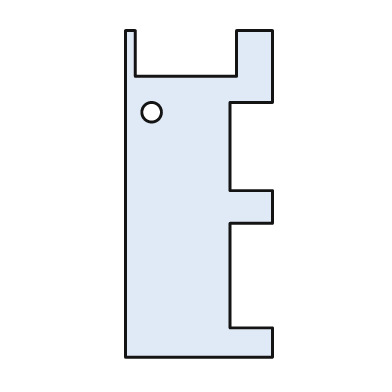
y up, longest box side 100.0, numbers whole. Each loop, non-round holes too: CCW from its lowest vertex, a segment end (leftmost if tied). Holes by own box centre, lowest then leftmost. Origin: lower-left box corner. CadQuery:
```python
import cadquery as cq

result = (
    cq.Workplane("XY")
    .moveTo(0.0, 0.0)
    .lineTo(45.0, 0.0)
    .lineTo(45.0, 9.0)
    .lineTo(32.0, 9.0)
    .lineTo(32.0, 41.0)
    .lineTo(45.0, 41.0)
    .lineTo(45.0, 51.0)
    .lineTo(32.0, 51.0)
    .lineTo(32.0, 78.0)
    .lineTo(45.0, 78.0)
    .lineTo(45.0, 100.0)
    .lineTo(34.0, 100.0)
    .lineTo(34.0, 86.0)
    .lineTo(3.0, 86.0)
    .lineTo(3.0, 100.0)
    .lineTo(0.0, 100.0)
    .close()
    .moveTo(8.0, 75.0)
    .circle(3.0)
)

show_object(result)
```